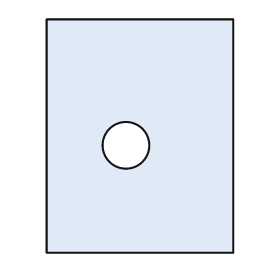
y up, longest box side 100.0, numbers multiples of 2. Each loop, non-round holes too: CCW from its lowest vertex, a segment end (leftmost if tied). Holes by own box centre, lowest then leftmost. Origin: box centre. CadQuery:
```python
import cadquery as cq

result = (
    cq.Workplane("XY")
    .moveTo(-40.0, -50.0)
    .lineTo(40.0, -50.0)
    .lineTo(40.0, 50.0)
    .lineTo(-40.0, 50.0)
    .close()
    .moveTo(-6.0, -4.0)
    .circle(10.0)
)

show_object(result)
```